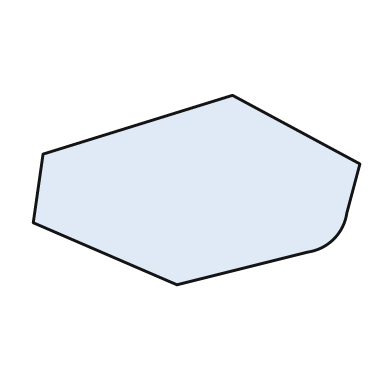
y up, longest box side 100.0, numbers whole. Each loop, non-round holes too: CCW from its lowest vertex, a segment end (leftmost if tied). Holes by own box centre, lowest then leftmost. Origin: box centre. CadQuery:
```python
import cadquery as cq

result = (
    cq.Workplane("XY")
    .moveTo(-6.0, -29.0)
    .lineTo(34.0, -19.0)
    .threePointArc((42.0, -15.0), (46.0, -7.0))
    .lineTo(50.0, 8.0)
    .lineTo(11.0, 29.0)
    .lineTo(-47.0, 11.0)
    .lineTo(-50.0, -10.0)
    .close()
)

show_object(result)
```